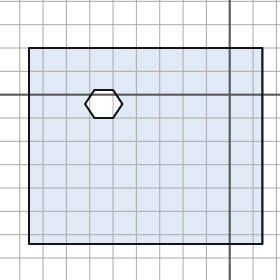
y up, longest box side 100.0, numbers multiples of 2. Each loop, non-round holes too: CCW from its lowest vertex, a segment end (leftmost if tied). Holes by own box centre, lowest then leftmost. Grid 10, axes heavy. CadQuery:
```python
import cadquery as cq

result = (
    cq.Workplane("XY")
    .moveTo(-86.0, -64.0)
    .lineTo(14.0, -64.0)
    .lineTo(14.0, 20.0)
    .lineTo(-86.0, 20.0)
    .close()
    .moveTo(-58.0, -10.0)
    .lineTo(-50.0, -10.0)
    .lineTo(-46.0, -4.0)
    .lineTo(-50.0, 2.0)
    .lineTo(-58.0, 2.0)
    .lineTo(-62.0, -4.0)
    .close()
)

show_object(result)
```